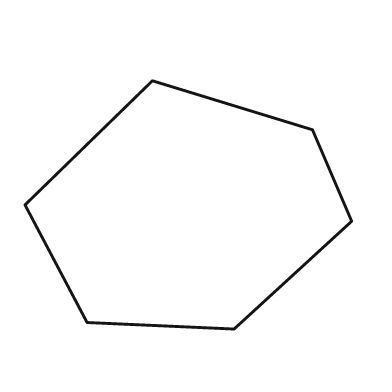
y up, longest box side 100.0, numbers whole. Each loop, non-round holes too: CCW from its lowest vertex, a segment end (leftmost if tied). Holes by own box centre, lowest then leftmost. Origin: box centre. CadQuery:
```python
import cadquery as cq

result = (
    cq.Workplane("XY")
    .moveTo(14.0, -38.0)
    .lineTo(50.0, -5.0)
    .lineTo(38.0, 23.0)
    .lineTo(-11.0, 38.0)
    .lineTo(-50.0, 0.0)
    .lineTo(-31.0, -36.0)
    .close()
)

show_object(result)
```